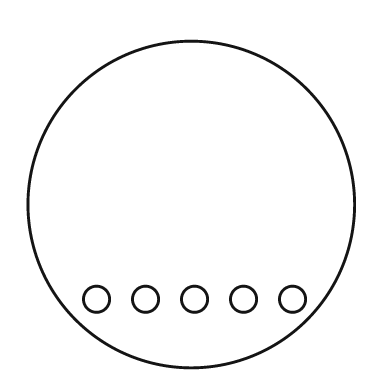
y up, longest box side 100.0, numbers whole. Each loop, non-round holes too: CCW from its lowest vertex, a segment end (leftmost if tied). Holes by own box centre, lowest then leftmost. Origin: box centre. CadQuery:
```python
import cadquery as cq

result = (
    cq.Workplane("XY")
    .moveTo(0.0, 0.0)
    .circle(50.0)
    .moveTo(-29.0, -29.0)
    .circle(4.0)
    .moveTo(-14.0, -29.0)
    .circle(4.0)
    .moveTo(1.0, -29.0)
    .circle(4.0)
    .moveTo(16.0, -29.0)
    .circle(4.0)
    .moveTo(31.0, -29.0)
    .circle(4.0)
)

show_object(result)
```